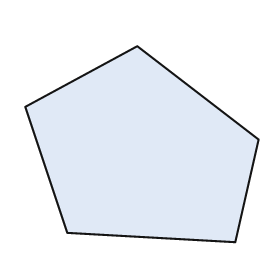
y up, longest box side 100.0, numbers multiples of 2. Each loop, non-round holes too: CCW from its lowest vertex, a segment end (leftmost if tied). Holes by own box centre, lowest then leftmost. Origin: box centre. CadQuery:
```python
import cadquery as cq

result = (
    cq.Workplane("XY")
    .moveTo(40.0, -42.0)
    .lineTo(50.0, 2.0)
    .lineTo(-2.0, 42.0)
    .lineTo(-50.0, 16.0)
    .lineTo(-32.0, -38.0)
    .close()
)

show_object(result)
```